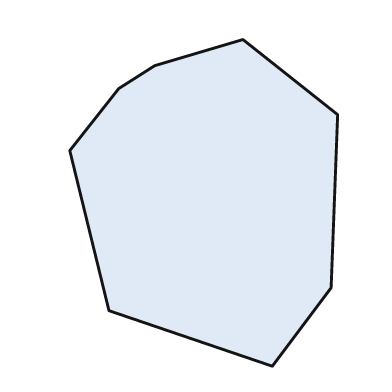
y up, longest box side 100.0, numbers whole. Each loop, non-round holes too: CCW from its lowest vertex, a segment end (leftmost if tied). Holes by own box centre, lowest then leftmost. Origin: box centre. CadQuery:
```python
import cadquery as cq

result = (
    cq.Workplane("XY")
    .moveTo(21.0, -50.0)
    .lineTo(39.0, -26.0)
    .lineTo(41.0, 27.0)
    .lineTo(12.0, 50.0)
    .lineTo(-15.0, 42.0)
    .lineTo(-26.0, 35.0)
    .lineTo(-41.0, 16.0)
    .lineTo(-29.0, -33.0)
    .close()
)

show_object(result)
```